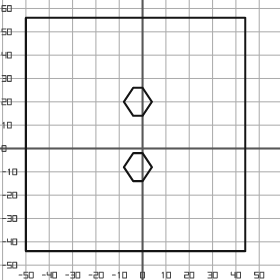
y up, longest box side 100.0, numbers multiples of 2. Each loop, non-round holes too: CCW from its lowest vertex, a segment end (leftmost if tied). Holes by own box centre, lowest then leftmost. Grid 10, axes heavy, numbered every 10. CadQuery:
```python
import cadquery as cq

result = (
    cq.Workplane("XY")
    .moveTo(-50.0, -44.0)
    .lineTo(44.0, -44.0)
    .lineTo(44.0, 56.0)
    .lineTo(-50.0, 56.0)
    .close()
    .moveTo(-4.0, -14.0)
    .lineTo(0.0, -14.0)
    .lineTo(4.0, -8.0)
    .lineTo(0.0, -2.0)
    .lineTo(-4.0, -2.0)
    .lineTo(-8.0, -8.0)
    .close()
    .moveTo(-4.0, 14.0)
    .lineTo(0.0, 14.0)
    .lineTo(4.0, 20.0)
    .lineTo(0.0, 26.0)
    .lineTo(-4.0, 26.0)
    .lineTo(-8.0, 20.0)
    .close()
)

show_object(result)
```